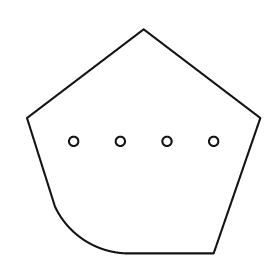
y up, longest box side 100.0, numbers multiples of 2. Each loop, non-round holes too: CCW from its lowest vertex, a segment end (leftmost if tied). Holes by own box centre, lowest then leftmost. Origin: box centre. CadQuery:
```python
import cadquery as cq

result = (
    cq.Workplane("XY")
    .moveTo(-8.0, -48.0)
    .lineTo(30.0, -48.0)
    .lineTo(50.0, 10.0)
    .lineTo(0.0, 48.0)
    .lineTo(-50.0, 10.0)
    .lineTo(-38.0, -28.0)
    .threePointArc((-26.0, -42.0), (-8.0, -48.0))
    .close()
    .moveTo(-30.0, 0.0)
    .circle(2.0)
    .moveTo(-10.0, 0.0)
    .circle(2.0)
    .moveTo(10.0, 0.0)
    .circle(2.0)
    .moveTo(30.0, 0.0)
    .circle(2.0)
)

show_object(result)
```